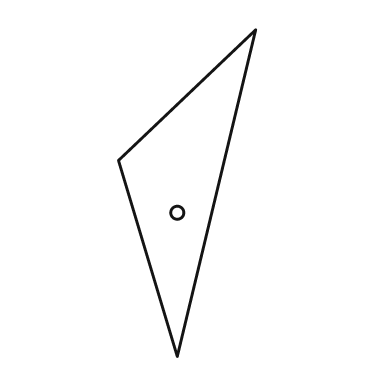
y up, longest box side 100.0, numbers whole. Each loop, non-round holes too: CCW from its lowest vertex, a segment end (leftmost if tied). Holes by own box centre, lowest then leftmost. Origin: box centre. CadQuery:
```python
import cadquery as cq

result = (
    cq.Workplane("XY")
    .moveTo(-3.0, -50.0)
    .lineTo(21.0, 50.0)
    .lineTo(-21.0, 10.0)
    .close()
    .moveTo(-3.0, -6.0)
    .circle(2.0)
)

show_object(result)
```